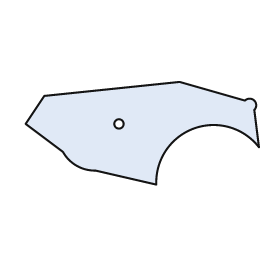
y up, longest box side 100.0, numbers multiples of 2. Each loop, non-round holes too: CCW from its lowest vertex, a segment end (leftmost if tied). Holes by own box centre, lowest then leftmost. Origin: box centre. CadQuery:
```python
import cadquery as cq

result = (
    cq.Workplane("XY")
    .moveTo(6.0, -22.0)
    .threePointArc((22.0, 2.0), (50.0, -6.0))
    .lineTo(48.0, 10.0)
    .threePointArc((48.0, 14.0), (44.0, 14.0))
    .lineTo(16.0, 22.0)
    .lineTo(-42.0, 16.0)
    .lineTo(-50.0, 4.0)
    .lineTo(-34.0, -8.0)
    .threePointArc((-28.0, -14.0), (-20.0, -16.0))
    .close()
    .moveTo(-10.0, 4.0)
    .circle(2.0)
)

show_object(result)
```